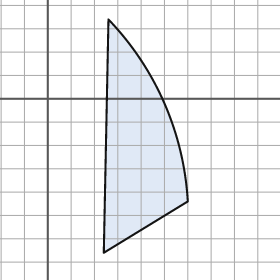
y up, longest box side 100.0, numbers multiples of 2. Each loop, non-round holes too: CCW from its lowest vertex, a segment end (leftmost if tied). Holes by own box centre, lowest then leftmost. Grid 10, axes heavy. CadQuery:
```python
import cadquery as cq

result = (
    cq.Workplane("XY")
    .moveTo(24.0, -66.0)
    .lineTo(60.0, -44.0)
    .threePointArc((50.0, -2.0), (26.0, 34.0))
    .close()
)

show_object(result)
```